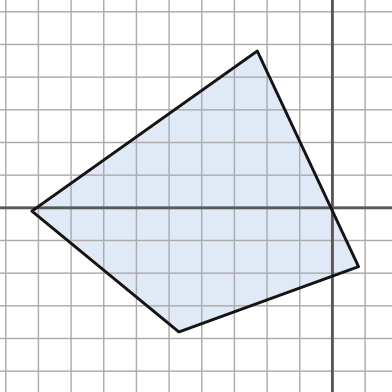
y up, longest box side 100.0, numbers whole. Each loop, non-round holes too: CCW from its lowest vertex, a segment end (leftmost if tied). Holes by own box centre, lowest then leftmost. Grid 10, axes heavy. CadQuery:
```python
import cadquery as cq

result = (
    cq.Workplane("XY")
    .moveTo(-47.0, -38.0)
    .lineTo(8.0, -18.0)
    .lineTo(-23.0, 48.0)
    .lineTo(-92.0, -1.0)
    .close()
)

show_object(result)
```